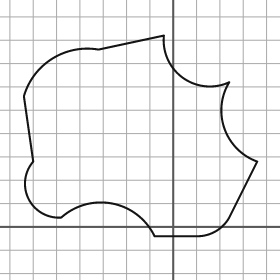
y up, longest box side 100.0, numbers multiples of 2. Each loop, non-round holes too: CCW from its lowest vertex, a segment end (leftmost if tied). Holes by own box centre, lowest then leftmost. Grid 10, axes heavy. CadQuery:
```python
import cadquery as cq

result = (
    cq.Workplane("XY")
    .moveTo(-8.0, -4.0)
    .lineTo(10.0, -4.0)
    .threePointArc((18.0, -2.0), (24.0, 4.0))
    .lineTo(36.0, 28.0)
    .threePointArc((22.0, 42.0), (24.0, 62.0))
    .threePointArc((4.0, 64.0), (-4.0, 82.0))
    .lineTo(-32.0, 76.0)
    .threePointArc((-52.0, 72.0), (-64.0, 56.0))
    .lineTo(-60.0, 28.0)
    .threePointArc((-62.0, 12.0), (-48.0, 4.0))
    .threePointArc((-26.0, 10.0), (-8.0, -4.0))
    .close()
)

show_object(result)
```